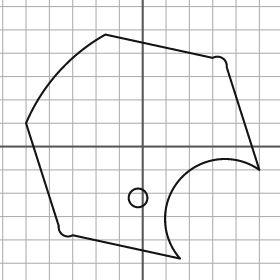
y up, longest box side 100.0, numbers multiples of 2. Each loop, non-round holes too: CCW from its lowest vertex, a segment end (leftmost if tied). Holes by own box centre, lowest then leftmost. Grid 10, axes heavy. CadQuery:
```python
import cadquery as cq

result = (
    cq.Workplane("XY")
    .moveTo(16.0, -48.0)
    .threePointArc((16.0, -14.0), (50.0, -10.0))
    .lineTo(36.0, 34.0)
    .threePointArc((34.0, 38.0), (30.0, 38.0))
    .lineTo(-16.0, 48.0)
    .threePointArc((-36.0, 32.0), (-50.0, 10.0))
    .lineTo(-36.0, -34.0)
    .threePointArc((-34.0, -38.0), (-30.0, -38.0))
    .close()
    .moveTo(-2.0, -22.0)
    .circle(4.0)
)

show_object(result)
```